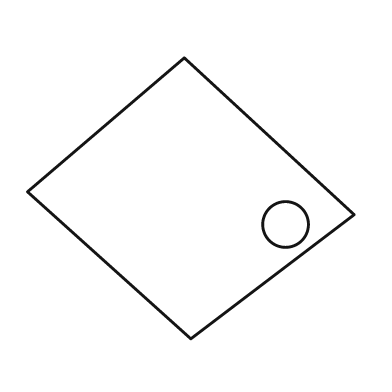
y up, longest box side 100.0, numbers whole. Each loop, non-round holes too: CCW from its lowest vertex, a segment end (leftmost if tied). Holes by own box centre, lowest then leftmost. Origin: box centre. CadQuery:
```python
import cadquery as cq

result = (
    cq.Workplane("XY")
    .moveTo(0.0, -43.0)
    .lineTo(50.0, -5.0)
    .lineTo(-2.0, 43.0)
    .lineTo(-50.0, 2.0)
    .close()
    .moveTo(29.0, -8.0)
    .circle(7.0)
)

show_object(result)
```